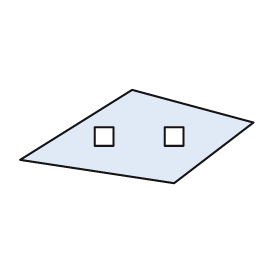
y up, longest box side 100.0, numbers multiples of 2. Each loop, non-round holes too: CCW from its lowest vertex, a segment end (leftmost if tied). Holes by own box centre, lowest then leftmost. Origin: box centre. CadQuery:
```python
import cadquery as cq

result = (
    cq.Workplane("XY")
    .moveTo(16.0, -20.0)
    .lineTo(50.0, 6.0)
    .lineTo(-2.0, 20.0)
    .lineTo(-50.0, -10.0)
    .close()
    .moveTo(-18.0, -4.0)
    .lineTo(-10.0, -4.0)
    .lineTo(-10.0, 4.0)
    .lineTo(-18.0, 4.0)
    .close()
    .moveTo(12.0, -4.0)
    .lineTo(20.0, -4.0)
    .lineTo(20.0, 4.0)
    .lineTo(12.0, 4.0)
    .close()
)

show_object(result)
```